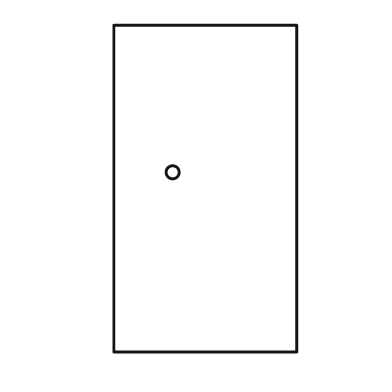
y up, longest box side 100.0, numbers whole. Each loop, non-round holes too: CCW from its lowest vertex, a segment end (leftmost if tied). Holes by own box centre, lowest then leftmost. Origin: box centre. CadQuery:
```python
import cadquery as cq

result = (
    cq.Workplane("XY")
    .moveTo(-28.0, -50.0)
    .lineTo(28.0, -50.0)
    .lineTo(28.0, 50.0)
    .lineTo(-28.0, 50.0)
    .close()
    .moveTo(-10.0, 5.0)
    .circle(2.0)
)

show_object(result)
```